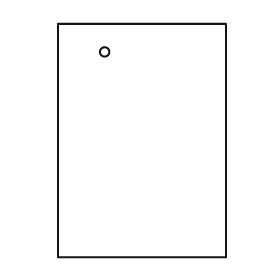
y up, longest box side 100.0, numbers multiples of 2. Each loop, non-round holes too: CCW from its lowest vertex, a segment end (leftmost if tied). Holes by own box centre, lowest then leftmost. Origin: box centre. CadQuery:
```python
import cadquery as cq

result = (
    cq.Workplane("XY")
    .moveTo(-36.0, -50.0)
    .lineTo(36.0, -50.0)
    .lineTo(36.0, 50.0)
    .lineTo(-36.0, 50.0)
    .close()
    .moveTo(-16.0, 38.0)
    .circle(2.0)
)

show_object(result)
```